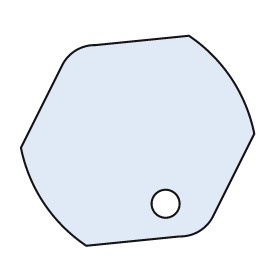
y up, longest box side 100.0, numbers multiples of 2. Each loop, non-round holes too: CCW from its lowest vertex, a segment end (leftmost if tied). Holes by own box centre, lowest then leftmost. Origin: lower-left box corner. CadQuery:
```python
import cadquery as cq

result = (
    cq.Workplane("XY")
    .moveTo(28.0, 0.0)
    .lineTo(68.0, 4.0)
    .threePointArc((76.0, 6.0), (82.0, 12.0))
    .lineTo(100.0, 48.0)
    .threePointArc((90.0, 72.0), (72.0, 90.0))
    .lineTo(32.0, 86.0)
    .threePointArc((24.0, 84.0), (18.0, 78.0))
    .lineTo(0.0, 42.0)
    .threePointArc((10.0, 18.0), (28.0, 0.0))
    .close()
    .moveTo(62.0, 18.0)
    .circle(6.0)
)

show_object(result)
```